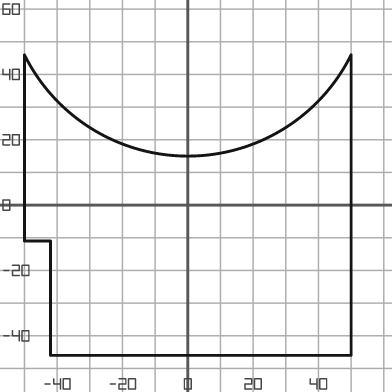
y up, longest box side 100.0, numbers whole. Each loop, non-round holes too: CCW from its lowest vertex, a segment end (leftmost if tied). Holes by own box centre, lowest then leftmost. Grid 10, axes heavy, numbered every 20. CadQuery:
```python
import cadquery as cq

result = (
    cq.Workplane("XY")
    .moveTo(-42.0, -46.0)
    .lineTo(50.0, -46.0)
    .lineTo(50.0, 46.0)
    .threePointArc((0.0, 15.0), (-50.0, 46.0))
    .lineTo(-50.0, -11.0)
    .lineTo(-42.0, -11.0)
    .close()
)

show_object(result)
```